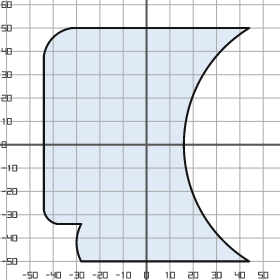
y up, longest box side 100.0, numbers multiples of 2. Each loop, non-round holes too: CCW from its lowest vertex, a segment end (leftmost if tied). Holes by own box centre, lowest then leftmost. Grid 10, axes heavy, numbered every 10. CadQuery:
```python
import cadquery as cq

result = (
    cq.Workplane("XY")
    .moveTo(-28.0, -50.0)
    .lineTo(44.0, -50.0)
    .threePointArc((16.0, 0.0), (44.0, 50.0))
    .lineTo(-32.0, 50.0)
    .threePointArc((-40.0, 46.0), (-44.0, 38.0))
    .lineTo(-44.0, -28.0)
    .threePointArc((-42.0, -32.0), (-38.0, -34.0))
    .lineTo(-28.0, -34.0)
    .threePointArc((-30.0, -42.0), (-28.0, -50.0))
    .close()
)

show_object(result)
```